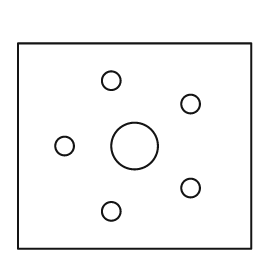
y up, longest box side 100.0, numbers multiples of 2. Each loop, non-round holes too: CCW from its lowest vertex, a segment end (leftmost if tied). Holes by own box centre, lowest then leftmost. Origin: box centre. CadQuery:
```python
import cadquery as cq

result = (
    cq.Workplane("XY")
    .moveTo(-50.0, -44.0)
    .lineTo(50.0, -44.0)
    .lineTo(50.0, 44.0)
    .lineTo(-50.0, 44.0)
    .close()
    .moveTo(-10.0, -28.0)
    .circle(4.0)
    .moveTo(24.0, -18.0)
    .circle(4.0)
    .moveTo(-30.0, 0.0)
    .circle(4.0)
    .moveTo(0.0, 0.0)
    .circle(10.0)
    .moveTo(24.0, 18.0)
    .circle(4.0)
    .moveTo(-10.0, 28.0)
    .circle(4.0)
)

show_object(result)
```